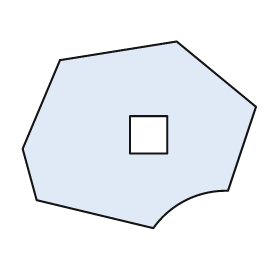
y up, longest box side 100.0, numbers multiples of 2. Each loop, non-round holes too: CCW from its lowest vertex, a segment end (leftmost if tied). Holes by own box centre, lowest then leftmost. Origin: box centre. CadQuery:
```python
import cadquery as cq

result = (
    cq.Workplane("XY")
    .moveTo(6.0, -40.0)
    .threePointArc((20.0, -28.0), (38.0, -24.0))
    .lineTo(50.0, 12.0)
    .lineTo(16.0, 40.0)
    .lineTo(-34.0, 32.0)
    .lineTo(-50.0, -6.0)
    .lineTo(-44.0, -28.0)
    .close()
    .moveTo(-4.0, -8.0)
    .lineTo(12.0, -8.0)
    .lineTo(12.0, 8.0)
    .lineTo(-4.0, 8.0)
    .close()
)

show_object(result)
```